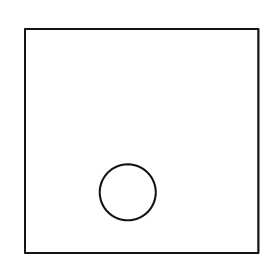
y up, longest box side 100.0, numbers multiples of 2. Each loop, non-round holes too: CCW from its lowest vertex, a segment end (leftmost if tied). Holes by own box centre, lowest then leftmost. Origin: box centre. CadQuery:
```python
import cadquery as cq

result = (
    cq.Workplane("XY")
    .moveTo(-50.0, -48.0)
    .lineTo(50.0, -48.0)
    .lineTo(50.0, 48.0)
    .lineTo(-50.0, 48.0)
    .close()
    .moveTo(-6.0, -22.0)
    .circle(12.0)
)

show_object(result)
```